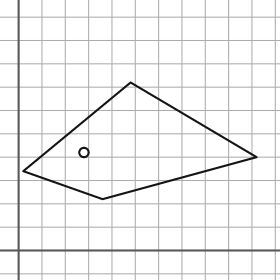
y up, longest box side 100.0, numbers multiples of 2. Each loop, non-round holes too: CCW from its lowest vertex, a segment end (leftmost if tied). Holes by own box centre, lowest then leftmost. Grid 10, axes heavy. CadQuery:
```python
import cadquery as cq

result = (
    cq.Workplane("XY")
    .moveTo(36.0, 22.0)
    .lineTo(102.0, 40.0)
    .lineTo(48.0, 72.0)
    .lineTo(2.0, 34.0)
    .close()
    .moveTo(28.0, 42.0)
    .circle(2.0)
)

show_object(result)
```